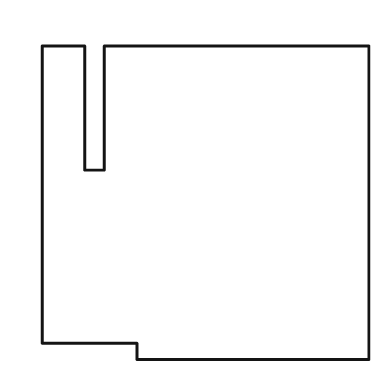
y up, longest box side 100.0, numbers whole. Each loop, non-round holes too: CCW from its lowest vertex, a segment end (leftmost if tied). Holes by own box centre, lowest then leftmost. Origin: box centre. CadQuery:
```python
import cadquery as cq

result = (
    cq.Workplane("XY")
    .moveTo(-21.0, -48.0)
    .lineTo(50.0, -48.0)
    .lineTo(50.0, 48.0)
    .lineTo(-31.0, 48.0)
    .lineTo(-31.0, 10.0)
    .lineTo(-37.0, 10.0)
    .lineTo(-37.0, 48.0)
    .lineTo(-50.0, 48.0)
    .lineTo(-50.0, -43.0)
    .lineTo(-21.0, -43.0)
    .close()
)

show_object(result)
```